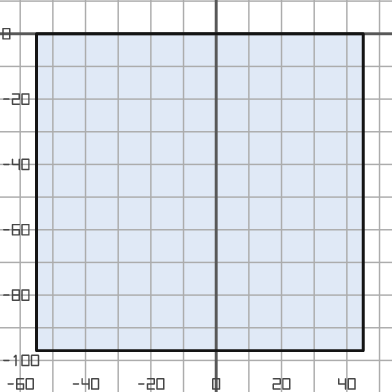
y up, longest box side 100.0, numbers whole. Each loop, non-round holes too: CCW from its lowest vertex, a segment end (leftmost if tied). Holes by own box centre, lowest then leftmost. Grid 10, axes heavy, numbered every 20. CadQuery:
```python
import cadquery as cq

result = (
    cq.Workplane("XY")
    .moveTo(-55.0, -97.0)
    .lineTo(45.0, -97.0)
    .lineTo(45.0, 0.0)
    .lineTo(-55.0, 0.0)
    .close()
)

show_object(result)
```